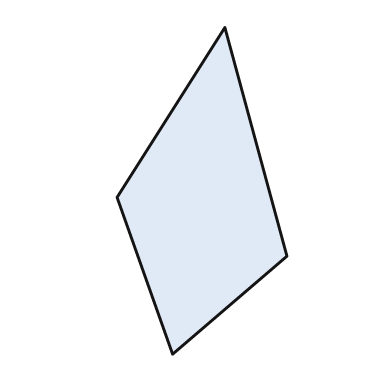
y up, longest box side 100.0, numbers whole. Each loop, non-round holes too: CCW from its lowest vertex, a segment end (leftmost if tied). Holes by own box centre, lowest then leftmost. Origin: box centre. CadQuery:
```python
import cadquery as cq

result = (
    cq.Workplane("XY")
    .moveTo(-9.0, -50.0)
    .lineTo(26.0, -20.0)
    .lineTo(7.0, 50.0)
    .lineTo(-26.0, -2.0)
    .close()
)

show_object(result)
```